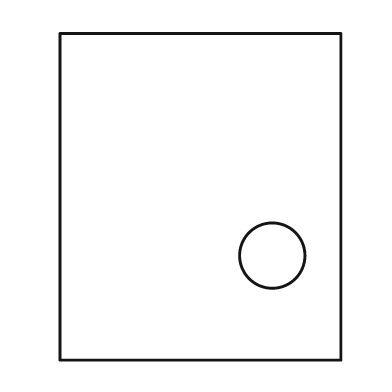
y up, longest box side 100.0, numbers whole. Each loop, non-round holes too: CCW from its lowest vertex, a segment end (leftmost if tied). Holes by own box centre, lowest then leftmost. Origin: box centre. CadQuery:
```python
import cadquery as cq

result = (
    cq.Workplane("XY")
    .moveTo(-43.0, -50.0)
    .lineTo(43.0, -50.0)
    .lineTo(43.0, 50.0)
    .lineTo(-43.0, 50.0)
    .close()
    .moveTo(22.0, -18.0)
    .circle(10.0)
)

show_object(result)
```